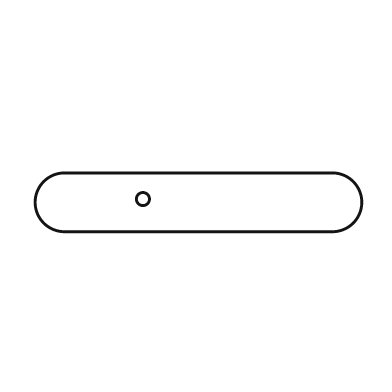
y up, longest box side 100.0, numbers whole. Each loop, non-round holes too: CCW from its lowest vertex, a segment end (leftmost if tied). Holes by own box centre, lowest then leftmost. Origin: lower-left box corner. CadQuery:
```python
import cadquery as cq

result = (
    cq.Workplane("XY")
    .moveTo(9.0, 0.0)
    .lineTo(91.0, 0.0)
    .threePointArc((100.0, 9.0), (91.0, 18.0))
    .lineTo(9.0, 18.0)
    .threePointArc((0.0, 9.0), (9.0, 0.0))
    .close()
    .moveTo(33.0, 10.0)
    .circle(2.0)
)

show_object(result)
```